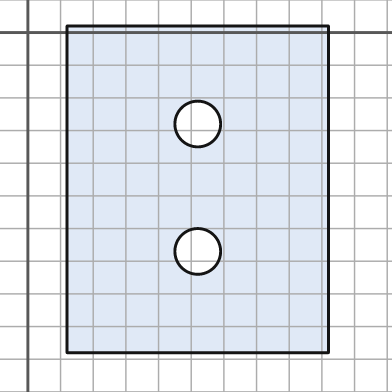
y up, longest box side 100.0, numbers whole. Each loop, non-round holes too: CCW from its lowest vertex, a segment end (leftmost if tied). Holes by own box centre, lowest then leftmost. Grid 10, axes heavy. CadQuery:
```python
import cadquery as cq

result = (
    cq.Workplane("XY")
    .moveTo(12.0, -98.0)
    .lineTo(92.0, -98.0)
    .lineTo(92.0, 2.0)
    .lineTo(12.0, 2.0)
    .close()
    .moveTo(52.0, -67.0)
    .circle(7.0)
    .moveTo(52.0, -28.0)
    .circle(7.0)
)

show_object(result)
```